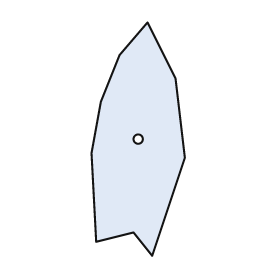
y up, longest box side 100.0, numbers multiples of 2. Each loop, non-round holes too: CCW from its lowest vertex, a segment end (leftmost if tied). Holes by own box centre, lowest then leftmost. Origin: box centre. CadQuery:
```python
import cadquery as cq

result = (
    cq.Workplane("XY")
    .moveTo(6.0, -50.0)
    .lineTo(20.0, -8.0)
    .lineTo(16.0, 26.0)
    .lineTo(4.0, 50.0)
    .lineTo(-8.0, 36.0)
    .lineTo(-16.0, 16.0)
    .lineTo(-20.0, -6.0)
    .lineTo(-18.0, -44.0)
    .lineTo(-2.0, -40.0)
    .close()
    .moveTo(0.0, 0.0)
    .circle(2.0)
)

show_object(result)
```